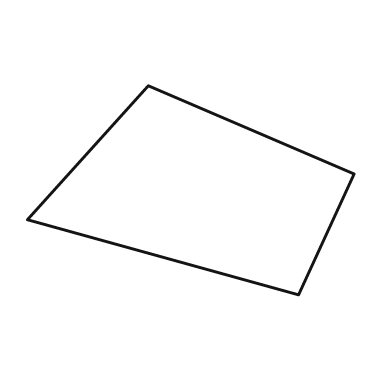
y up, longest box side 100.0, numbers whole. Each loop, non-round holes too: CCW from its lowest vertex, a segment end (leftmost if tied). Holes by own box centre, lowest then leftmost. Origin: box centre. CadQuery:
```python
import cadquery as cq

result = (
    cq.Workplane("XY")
    .moveTo(33.0, -32.0)
    .lineTo(50.0, 5.0)
    .lineTo(-13.0, 32.0)
    .lineTo(-50.0, -9.0)
    .close()
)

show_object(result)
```